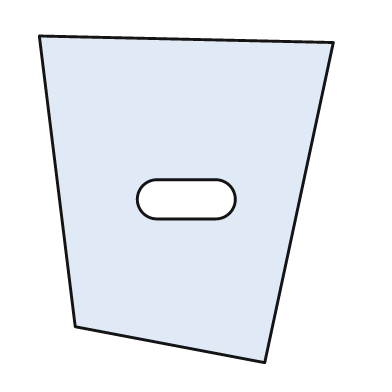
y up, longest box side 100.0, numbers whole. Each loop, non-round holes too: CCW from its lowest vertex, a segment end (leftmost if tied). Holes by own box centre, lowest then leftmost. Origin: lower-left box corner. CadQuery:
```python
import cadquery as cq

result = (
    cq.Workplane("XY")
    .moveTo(69.0, 0.0)
    .lineTo(90.0, 98.0)
    .lineTo(0.0, 100.0)
    .lineTo(11.0, 11.0)
    .close()
    .moveTo(36.0, 44.0)
    .lineTo(54.0, 44.0)
    .threePointArc((60.0, 50.0), (54.0, 56.0))
    .lineTo(36.0, 56.0)
    .threePointArc((30.0, 50.0), (36.0, 44.0))
    .close()
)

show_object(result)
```